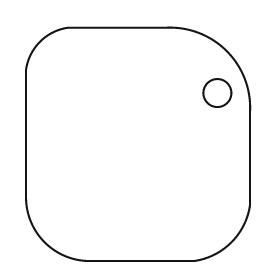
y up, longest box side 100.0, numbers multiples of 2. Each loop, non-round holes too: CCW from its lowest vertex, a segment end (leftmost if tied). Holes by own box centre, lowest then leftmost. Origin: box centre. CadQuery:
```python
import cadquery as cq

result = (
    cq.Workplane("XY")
    .moveTo(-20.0, -50.0)
    .lineTo(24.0, -50.0)
    .threePointArc((40.0, -42.0), (48.0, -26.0))
    .lineTo(48.0, 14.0)
    .threePointArc((38.0, 40.0), (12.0, 50.0))
    .lineTo(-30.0, 50.0)
    .threePointArc((-42.0, 44.0), (-48.0, 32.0))
    .lineTo(-48.0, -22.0)
    .threePointArc((-40.0, -42.0), (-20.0, -50.0))
    .close()
    .moveTo(34.0, 22.0)
    .circle(6.0)
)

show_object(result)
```